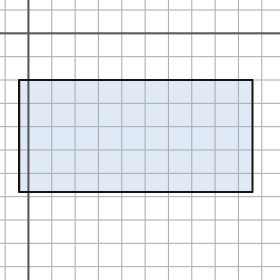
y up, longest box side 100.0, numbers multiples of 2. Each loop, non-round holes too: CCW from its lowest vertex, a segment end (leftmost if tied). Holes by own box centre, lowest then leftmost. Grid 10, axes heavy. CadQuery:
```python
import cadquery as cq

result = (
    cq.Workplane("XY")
    .moveTo(-4.0, -68.0)
    .lineTo(96.0, -68.0)
    .lineTo(96.0, -20.0)
    .lineTo(-4.0, -20.0)
    .close()
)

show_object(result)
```